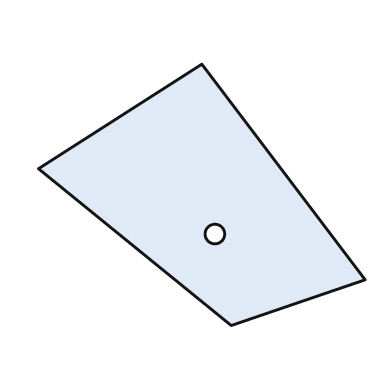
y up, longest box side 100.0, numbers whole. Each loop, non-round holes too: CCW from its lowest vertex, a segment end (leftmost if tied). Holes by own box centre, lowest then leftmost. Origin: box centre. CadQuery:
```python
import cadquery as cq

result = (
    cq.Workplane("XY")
    .moveTo(9.0, -40.0)
    .lineTo(50.0, -26.0)
    .lineTo(0.0, 40.0)
    .lineTo(-50.0, 8.0)
    .close()
    .moveTo(4.0, -12.0)
    .circle(3.0)
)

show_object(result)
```